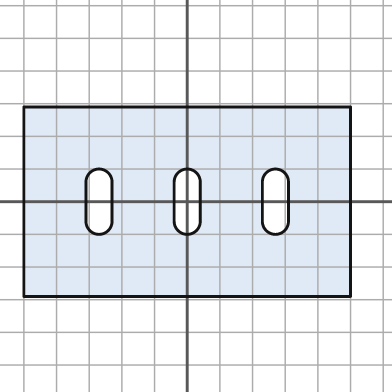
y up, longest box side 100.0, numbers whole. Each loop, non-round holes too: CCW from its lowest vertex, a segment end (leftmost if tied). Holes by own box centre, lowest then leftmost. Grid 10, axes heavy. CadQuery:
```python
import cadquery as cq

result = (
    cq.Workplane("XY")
    .moveTo(-50.0, -29.0)
    .lineTo(50.0, -29.0)
    .lineTo(50.0, 29.0)
    .lineTo(-50.0, 29.0)
    .close()
    .moveTo(-31.0, -6.0)
    .threePointArc((-27.0, -10.0), (-23.0, -6.0))
    .lineTo(-23.0, 6.0)
    .threePointArc((-27.0, 10.0), (-31.0, 6.0))
    .close()
    .moveTo(-4.0, -6.0)
    .threePointArc((0.0, -10.0), (4.0, -6.0))
    .lineTo(4.0, 6.0)
    .threePointArc((0.0, 10.0), (-4.0, 6.0))
    .close()
    .moveTo(23.0, -6.0)
    .threePointArc((27.0, -10.0), (31.0, -6.0))
    .lineTo(31.0, 6.0)
    .threePointArc((27.0, 10.0), (23.0, 6.0))
    .close()
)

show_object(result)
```